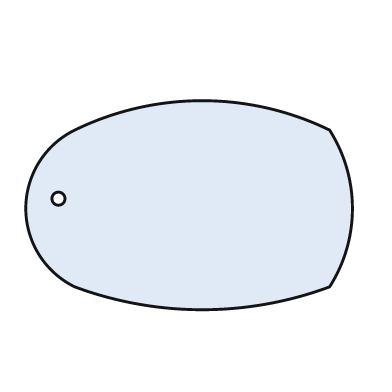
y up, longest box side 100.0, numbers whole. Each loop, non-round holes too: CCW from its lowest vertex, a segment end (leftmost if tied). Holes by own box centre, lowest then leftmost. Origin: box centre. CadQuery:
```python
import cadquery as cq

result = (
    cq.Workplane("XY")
    .moveTo(-35.0, -25.0)
    .threePointArc((4.0, -32.0), (43.0, -25.0))
    .threePointArc((50.0, -1.0), (43.0, 23.0))
    .threePointArc((4.0, 32.0), (-35.0, 23.0))
    .threePointArc((-50.0, -1.0), (-35.0, -25.0))
    .close()
    .moveTo(-40.0, 2.0)
    .circle(2.0)
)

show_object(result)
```